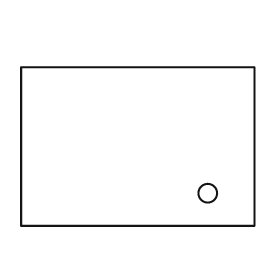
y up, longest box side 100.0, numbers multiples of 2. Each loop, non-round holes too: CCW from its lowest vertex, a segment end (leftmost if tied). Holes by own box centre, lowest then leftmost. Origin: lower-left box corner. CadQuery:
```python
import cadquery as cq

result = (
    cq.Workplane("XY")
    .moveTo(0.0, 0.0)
    .lineTo(100.0, 0.0)
    .lineTo(100.0, 68.0)
    .lineTo(0.0, 68.0)
    .close()
    .moveTo(80.0, 14.0)
    .circle(4.0)
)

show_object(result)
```